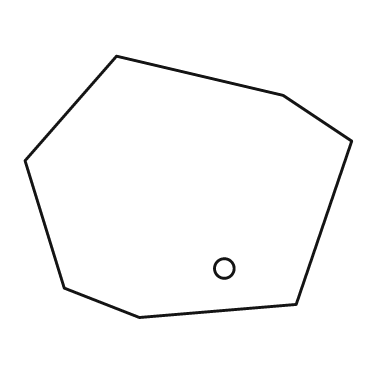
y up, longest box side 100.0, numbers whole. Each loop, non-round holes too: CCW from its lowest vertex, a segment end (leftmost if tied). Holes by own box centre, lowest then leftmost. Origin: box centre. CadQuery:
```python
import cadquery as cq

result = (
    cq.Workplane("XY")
    .moveTo(-15.0, -40.0)
    .lineTo(33.0, -36.0)
    .lineTo(50.0, 14.0)
    .lineTo(29.0, 28.0)
    .lineTo(-22.0, 40.0)
    .lineTo(-50.0, 8.0)
    .lineTo(-38.0, -31.0)
    .close()
    .moveTo(11.0, -25.0)
    .circle(3.0)
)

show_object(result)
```